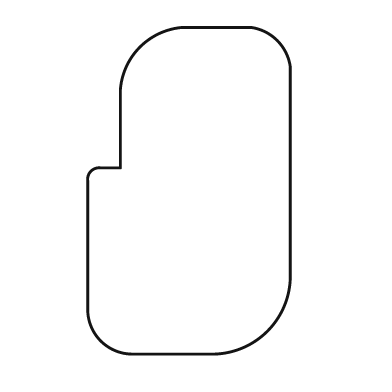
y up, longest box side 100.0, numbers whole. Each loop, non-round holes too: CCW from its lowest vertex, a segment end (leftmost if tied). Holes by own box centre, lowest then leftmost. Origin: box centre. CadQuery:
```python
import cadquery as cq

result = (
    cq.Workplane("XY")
    .moveTo(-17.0, -50.0)
    .lineTo(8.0, -50.0)
    .threePointArc((24.0, -43.0), (31.0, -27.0))
    .lineTo(31.0, 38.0)
    .threePointArc((27.0, 46.0), (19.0, 50.0))
    .lineTo(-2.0, 50.0)
    .threePointArc((-15.0, 44.0), (-21.0, 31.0))
    .lineTo(-21.0, 7.0)
    .lineTo(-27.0, 7.0)
    .threePointArc((-30.0, 6.0), (-31.0, 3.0))
    .lineTo(-31.0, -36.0)
    .threePointArc((-27.0, -46.0), (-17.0, -50.0))
    .close()
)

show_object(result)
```